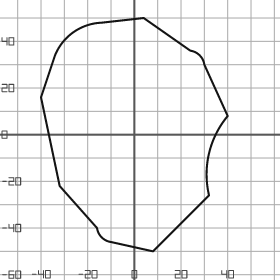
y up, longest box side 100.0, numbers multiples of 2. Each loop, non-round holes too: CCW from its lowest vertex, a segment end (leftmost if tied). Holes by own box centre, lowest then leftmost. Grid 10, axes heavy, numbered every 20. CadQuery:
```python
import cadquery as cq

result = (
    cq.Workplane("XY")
    .moveTo(8.0, -50.0)
    .lineTo(32.0, -26.0)
    .threePointArc((32.0, -8.0), (40.0, 8.0))
    .lineTo(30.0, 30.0)
    .threePointArc((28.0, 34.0), (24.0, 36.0))
    .lineTo(4.0, 50.0)
    .lineTo(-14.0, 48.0)
    .threePointArc((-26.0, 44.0), (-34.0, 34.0))
    .lineTo(-40.0, 16.0)
    .lineTo(-32.0, -22.0)
    .lineTo(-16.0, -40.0)
    .threePointArc((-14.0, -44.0), (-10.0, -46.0))
    .close()
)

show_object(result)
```